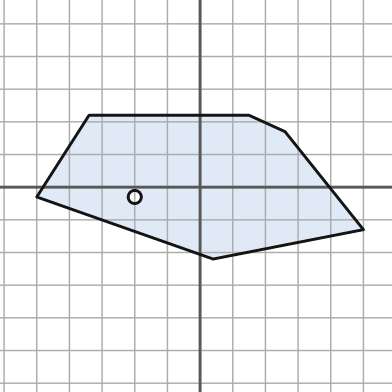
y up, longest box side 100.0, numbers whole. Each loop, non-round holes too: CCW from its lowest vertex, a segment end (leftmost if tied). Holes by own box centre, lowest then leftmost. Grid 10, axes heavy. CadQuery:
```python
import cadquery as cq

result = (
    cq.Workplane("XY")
    .moveTo(4.0, -22.0)
    .lineTo(50.0, -13.0)
    .lineTo(26.0, 17.0)
    .lineTo(15.0, 22.0)
    .lineTo(-34.0, 22.0)
    .lineTo(-50.0, -3.0)
    .close()
    .moveTo(-20.0, -3.0)
    .circle(2.0)
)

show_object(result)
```